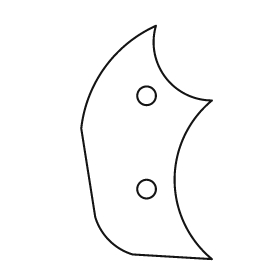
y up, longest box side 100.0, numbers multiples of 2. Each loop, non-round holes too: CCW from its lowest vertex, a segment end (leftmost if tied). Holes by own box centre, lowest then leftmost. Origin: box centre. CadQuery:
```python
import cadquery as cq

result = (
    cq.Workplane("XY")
    .moveTo(28.0, -50.0)
    .threePointArc((12.0, -16.0), (28.0, 18.0))
    .threePointArc((8.0, 28.0), (4.0, 50.0))
    .threePointArc((-18.0, 32.0), (-28.0, 6.0))
    .lineTo(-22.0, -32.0)
    .threePointArc((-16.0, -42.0), (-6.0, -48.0))
    .close()
    .moveTo(0.0, -20.0)
    .circle(4.0)
    .moveTo(0.0, 20.0)
    .circle(4.0)
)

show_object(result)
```